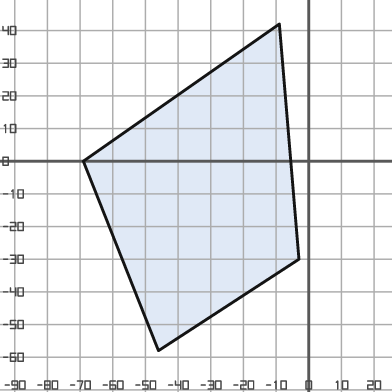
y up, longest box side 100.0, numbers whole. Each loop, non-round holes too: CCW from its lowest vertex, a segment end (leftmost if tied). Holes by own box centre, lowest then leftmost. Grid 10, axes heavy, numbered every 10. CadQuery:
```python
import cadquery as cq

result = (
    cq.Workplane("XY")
    .moveTo(-46.0, -58.0)
    .lineTo(-3.0, -30.0)
    .lineTo(-9.0, 42.0)
    .lineTo(-69.0, 0.0)
    .close()
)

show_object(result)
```